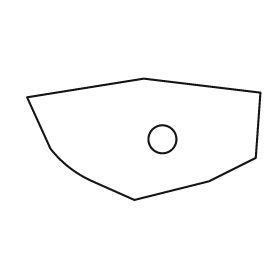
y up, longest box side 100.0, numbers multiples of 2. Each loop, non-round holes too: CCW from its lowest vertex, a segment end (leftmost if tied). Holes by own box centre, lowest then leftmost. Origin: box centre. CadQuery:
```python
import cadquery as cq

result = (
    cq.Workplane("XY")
    .moveTo(-4.0, -26.0)
    .lineTo(28.0, -18.0)
    .lineTo(48.0, -8.0)
    .lineTo(50.0, 20.0)
    .lineTo(0.0, 26.0)
    .lineTo(-50.0, 18.0)
    .lineTo(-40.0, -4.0)
    .threePointArc((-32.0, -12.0), (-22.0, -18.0))
    .close()
    .moveTo(8.0, 0.0)
    .circle(6.0)
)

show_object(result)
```